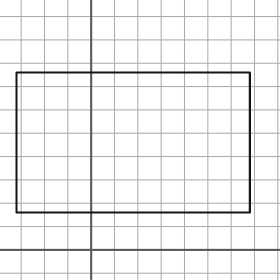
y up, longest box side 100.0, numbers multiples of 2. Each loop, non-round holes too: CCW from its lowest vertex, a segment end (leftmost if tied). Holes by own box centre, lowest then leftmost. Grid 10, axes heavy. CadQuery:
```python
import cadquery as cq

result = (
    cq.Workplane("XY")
    .moveTo(-32.0, 16.0)
    .lineTo(68.0, 16.0)
    .lineTo(68.0, 76.0)
    .lineTo(-32.0, 76.0)
    .close()
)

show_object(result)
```